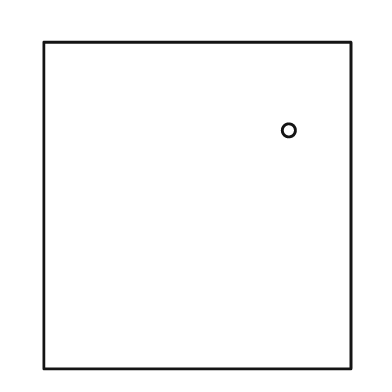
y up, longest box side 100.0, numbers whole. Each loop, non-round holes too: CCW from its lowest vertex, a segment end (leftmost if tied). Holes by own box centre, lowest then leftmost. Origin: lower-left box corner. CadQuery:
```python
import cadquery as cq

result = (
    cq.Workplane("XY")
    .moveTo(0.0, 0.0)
    .lineTo(94.0, 0.0)
    .lineTo(94.0, 100.0)
    .lineTo(0.0, 100.0)
    .close()
    .moveTo(75.0, 73.0)
    .circle(2.0)
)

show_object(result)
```